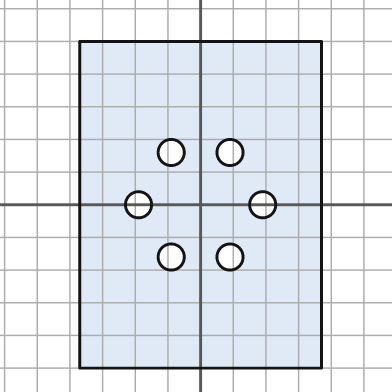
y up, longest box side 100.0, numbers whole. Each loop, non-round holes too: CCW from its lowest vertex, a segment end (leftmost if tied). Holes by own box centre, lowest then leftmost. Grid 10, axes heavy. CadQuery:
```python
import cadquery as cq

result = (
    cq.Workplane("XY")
    .moveTo(-37.0, -50.0)
    .lineTo(37.0, -50.0)
    .lineTo(37.0, 50.0)
    .lineTo(-37.0, 50.0)
    .close()
    .moveTo(-9.0, -16.0)
    .circle(4.0)
    .moveTo(9.0, -16.0)
    .circle(4.0)
    .moveTo(-19.0, 0.0)
    .circle(4.0)
    .moveTo(19.0, 0.0)
    .circle(4.0)
    .moveTo(-9.0, 16.0)
    .circle(4.0)
    .moveTo(9.0, 16.0)
    .circle(4.0)
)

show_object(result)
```